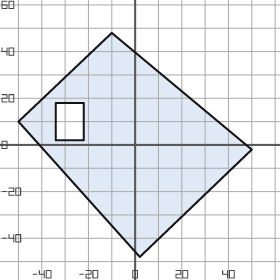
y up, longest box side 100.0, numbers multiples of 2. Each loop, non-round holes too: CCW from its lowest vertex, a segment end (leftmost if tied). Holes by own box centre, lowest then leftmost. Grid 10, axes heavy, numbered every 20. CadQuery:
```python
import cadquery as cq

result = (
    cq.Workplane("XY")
    .moveTo(2.0, -48.0)
    .lineTo(50.0, -2.0)
    .lineTo(-10.0, 48.0)
    .lineTo(-50.0, 10.0)
    .close()
    .moveTo(-34.0, 2.0)
    .lineTo(-22.0, 2.0)
    .lineTo(-22.0, 18.0)
    .lineTo(-34.0, 18.0)
    .close()
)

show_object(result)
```